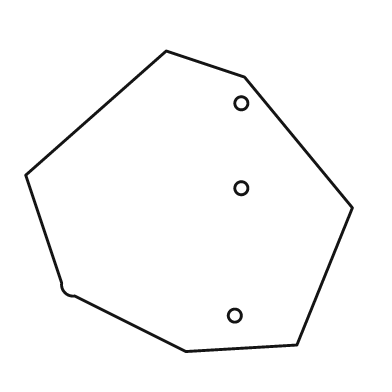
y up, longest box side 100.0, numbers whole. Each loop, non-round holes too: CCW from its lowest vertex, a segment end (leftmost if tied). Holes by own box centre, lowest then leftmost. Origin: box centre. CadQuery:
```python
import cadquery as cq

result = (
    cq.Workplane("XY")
    .moveTo(-1.0, -46.0)
    .lineTo(33.0, -44.0)
    .lineTo(50.0, -2.0)
    .lineTo(17.0, 38.0)
    .lineTo(-7.0, 46.0)
    .lineTo(-50.0, 8.0)
    .lineTo(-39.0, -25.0)
    .threePointArc((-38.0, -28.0), (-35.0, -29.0))
    .close()
    .moveTo(14.0, -35.0)
    .circle(2.0)
    .moveTo(16.0, 4.0)
    .circle(2.0)
    .moveTo(16.0, 30.0)
    .circle(2.0)
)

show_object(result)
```